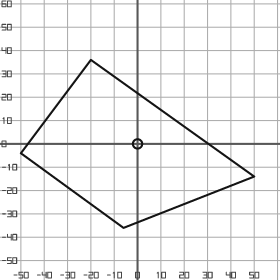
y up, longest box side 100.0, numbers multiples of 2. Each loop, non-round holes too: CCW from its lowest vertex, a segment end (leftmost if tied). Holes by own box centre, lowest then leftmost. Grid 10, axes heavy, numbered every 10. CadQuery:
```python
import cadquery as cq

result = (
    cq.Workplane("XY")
    .moveTo(-6.0, -36.0)
    .lineTo(50.0, -14.0)
    .lineTo(-20.0, 36.0)
    .lineTo(-50.0, -4.0)
    .close()
    .moveTo(0.0, 0.0)
    .circle(2.0)
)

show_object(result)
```